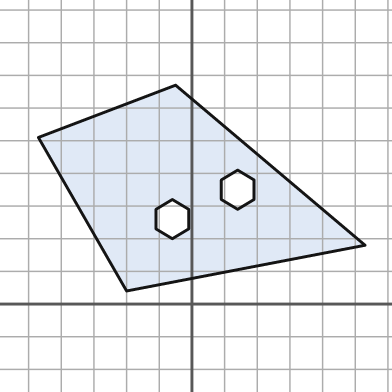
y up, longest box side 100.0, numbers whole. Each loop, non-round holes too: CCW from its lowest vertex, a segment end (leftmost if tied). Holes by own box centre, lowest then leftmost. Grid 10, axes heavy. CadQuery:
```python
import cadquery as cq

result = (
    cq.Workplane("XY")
    .moveTo(-20.0, 4.0)
    .lineTo(53.0, 18.0)
    .lineTo(-5.0, 67.0)
    .lineTo(-47.0, 51.0)
    .close()
    .moveTo(-6.0, 20.0)
    .lineTo(-1.0, 23.0)
    .lineTo(-1.0, 29.0)
    .lineTo(-6.0, 32.0)
    .lineTo(-11.0, 29.0)
    .lineTo(-11.0, 23.0)
    .close()
    .moveTo(14.0, 29.0)
    .lineTo(19.0, 32.0)
    .lineTo(19.0, 38.0)
    .lineTo(14.0, 41.0)
    .lineTo(9.0, 38.0)
    .lineTo(9.0, 32.0)
    .close()
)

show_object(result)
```